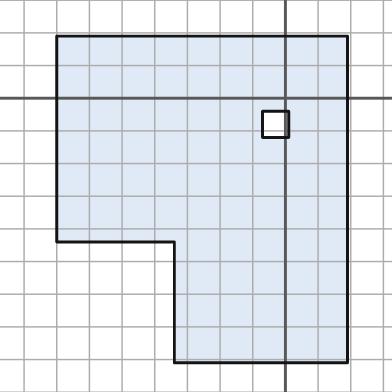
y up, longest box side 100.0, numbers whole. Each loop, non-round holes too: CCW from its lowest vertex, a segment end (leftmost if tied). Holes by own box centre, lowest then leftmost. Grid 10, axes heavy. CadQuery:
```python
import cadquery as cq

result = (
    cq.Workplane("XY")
    .moveTo(-34.0, -81.0)
    .lineTo(19.0, -81.0)
    .lineTo(19.0, 19.0)
    .lineTo(-70.0, 19.0)
    .lineTo(-70.0, -44.0)
    .lineTo(-34.0, -44.0)
    .close()
    .moveTo(-7.0, -12.0)
    .lineTo(1.0, -12.0)
    .lineTo(1.0, -4.0)
    .lineTo(-7.0, -4.0)
    .close()
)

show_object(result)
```